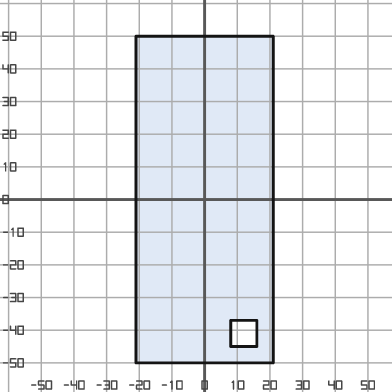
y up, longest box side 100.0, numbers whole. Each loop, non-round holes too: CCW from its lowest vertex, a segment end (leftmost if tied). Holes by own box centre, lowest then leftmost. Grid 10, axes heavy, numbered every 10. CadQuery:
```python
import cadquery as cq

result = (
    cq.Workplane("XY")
    .moveTo(-21.0, -50.0)
    .lineTo(21.0, -50.0)
    .lineTo(21.0, 50.0)
    .lineTo(-21.0, 50.0)
    .close()
    .moveTo(8.0, -45.0)
    .lineTo(16.0, -45.0)
    .lineTo(16.0, -37.0)
    .lineTo(8.0, -37.0)
    .close()
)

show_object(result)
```